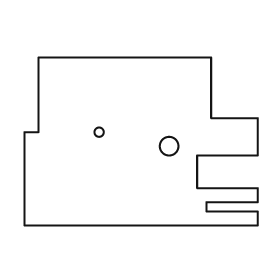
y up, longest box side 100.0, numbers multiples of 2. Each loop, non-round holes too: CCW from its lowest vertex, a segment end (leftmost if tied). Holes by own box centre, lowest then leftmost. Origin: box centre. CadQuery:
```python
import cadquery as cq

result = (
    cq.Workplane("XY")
    .moveTo(-50.0, -36.0)
    .lineTo(50.0, -36.0)
    .lineTo(50.0, -30.0)
    .lineTo(28.0, -30.0)
    .lineTo(28.0, -26.0)
    .lineTo(50.0, -26.0)
    .lineTo(50.0, -20.0)
    .lineTo(24.0, -20.0)
    .lineTo(24.0, -6.0)
    .lineTo(50.0, -6.0)
    .lineTo(50.0, 10.0)
    .lineTo(30.0, 10.0)
    .lineTo(30.0, 36.0)
    .lineTo(-44.0, 36.0)
    .lineTo(-44.0, 4.0)
    .lineTo(-50.0, 4.0)
    .close()
    .moveTo(12.0, -2.0)
    .circle(4.0)
    .moveTo(-18.0, 4.0)
    .circle(2.0)
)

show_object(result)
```